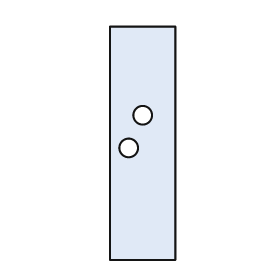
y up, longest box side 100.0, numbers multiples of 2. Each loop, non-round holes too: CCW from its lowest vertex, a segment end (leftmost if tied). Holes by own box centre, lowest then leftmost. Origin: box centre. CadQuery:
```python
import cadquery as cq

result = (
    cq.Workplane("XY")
    .moveTo(-14.0, -50.0)
    .lineTo(14.0, -50.0)
    .lineTo(14.0, 50.0)
    .lineTo(-14.0, 50.0)
    .close()
    .moveTo(-6.0, -2.0)
    .circle(4.0)
    .moveTo(0.0, 12.0)
    .circle(4.0)
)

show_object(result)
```